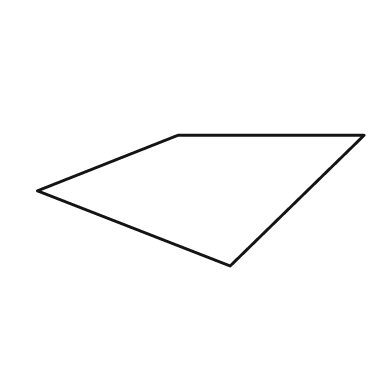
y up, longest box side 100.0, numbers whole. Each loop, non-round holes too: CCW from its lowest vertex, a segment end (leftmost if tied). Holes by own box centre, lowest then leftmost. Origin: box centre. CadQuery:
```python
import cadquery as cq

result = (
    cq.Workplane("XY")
    .moveTo(9.0, -20.0)
    .lineTo(50.0, 20.0)
    .lineTo(-7.0, 20.0)
    .lineTo(-50.0, 3.0)
    .close()
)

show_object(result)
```